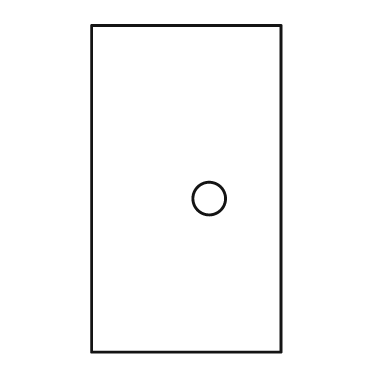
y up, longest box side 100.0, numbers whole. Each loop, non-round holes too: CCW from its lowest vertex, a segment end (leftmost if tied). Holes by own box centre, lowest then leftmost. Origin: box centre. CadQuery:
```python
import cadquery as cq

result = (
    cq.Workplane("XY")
    .moveTo(-29.0, -50.0)
    .lineTo(29.0, -50.0)
    .lineTo(29.0, 50.0)
    .lineTo(-29.0, 50.0)
    .close()
    .moveTo(7.0, -3.0)
    .circle(5.0)
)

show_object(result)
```